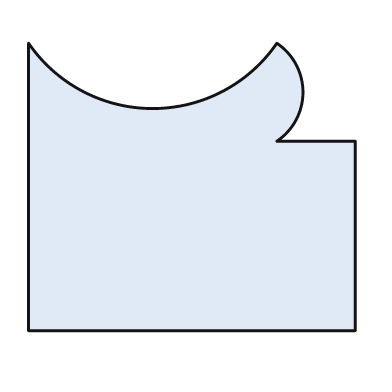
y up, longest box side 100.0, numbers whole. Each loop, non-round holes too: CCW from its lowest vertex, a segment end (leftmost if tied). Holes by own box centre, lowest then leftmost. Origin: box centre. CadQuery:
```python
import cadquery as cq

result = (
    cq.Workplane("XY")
    .moveTo(-50.0, -44.0)
    .lineTo(50.0, -44.0)
    .lineTo(50.0, 14.0)
    .lineTo(26.0, 14.0)
    .threePointArc((34.0, 29.0), (26.0, 44.0))
    .threePointArc((-12.0, 24.0), (-50.0, 44.0))
    .close()
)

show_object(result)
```